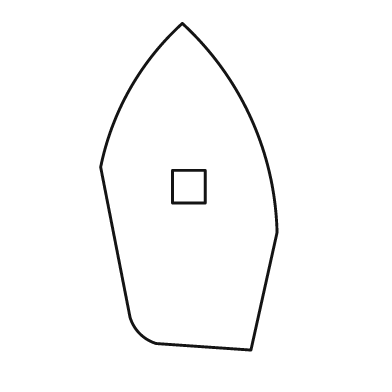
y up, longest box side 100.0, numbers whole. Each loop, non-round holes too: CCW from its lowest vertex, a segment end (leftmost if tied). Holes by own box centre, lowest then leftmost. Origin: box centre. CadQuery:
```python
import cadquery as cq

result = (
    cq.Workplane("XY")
    .moveTo(19.0, -50.0)
    .lineTo(27.0, -14.0)
    .threePointArc((19.0, 21.0), (-2.0, 50.0))
    .threePointArc((-18.0, 30.0), (-27.0, 6.0))
    .lineTo(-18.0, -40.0)
    .threePointArc((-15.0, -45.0), (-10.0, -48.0))
    .close()
    .moveTo(-5.0, -5.0)
    .lineTo(5.0, -5.0)
    .lineTo(5.0, 5.0)
    .lineTo(-5.0, 5.0)
    .close()
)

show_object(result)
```